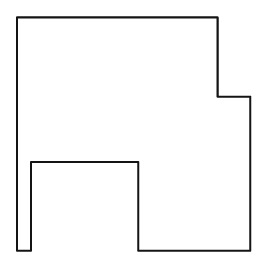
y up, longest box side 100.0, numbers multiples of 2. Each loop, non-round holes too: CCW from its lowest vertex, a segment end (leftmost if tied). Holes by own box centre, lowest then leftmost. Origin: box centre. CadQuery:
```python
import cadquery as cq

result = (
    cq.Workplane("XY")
    .moveTo(-50.0, -50.0)
    .lineTo(-44.0, -50.0)
    .lineTo(-44.0, -12.0)
    .lineTo(2.0, -12.0)
    .lineTo(2.0, -50.0)
    .lineTo(50.0, -50.0)
    .lineTo(50.0, 16.0)
    .lineTo(36.0, 16.0)
    .lineTo(36.0, 50.0)
    .lineTo(-50.0, 50.0)
    .close()
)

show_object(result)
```